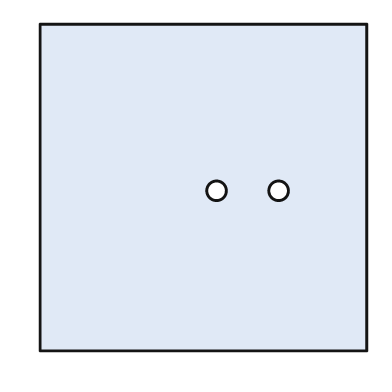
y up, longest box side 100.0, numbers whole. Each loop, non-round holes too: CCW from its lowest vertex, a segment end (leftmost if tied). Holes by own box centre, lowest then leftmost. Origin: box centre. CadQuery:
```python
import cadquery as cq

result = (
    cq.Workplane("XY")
    .moveTo(-50.0, -50.0)
    .lineTo(50.0, -50.0)
    .lineTo(50.0, 50.0)
    .lineTo(-50.0, 50.0)
    .close()
    .moveTo(4.0, -1.0)
    .circle(3.0)
    .moveTo(23.0, -1.0)
    .circle(3.0)
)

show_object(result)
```